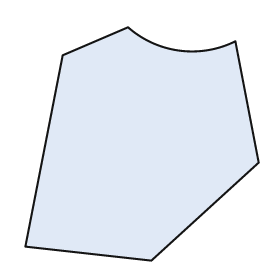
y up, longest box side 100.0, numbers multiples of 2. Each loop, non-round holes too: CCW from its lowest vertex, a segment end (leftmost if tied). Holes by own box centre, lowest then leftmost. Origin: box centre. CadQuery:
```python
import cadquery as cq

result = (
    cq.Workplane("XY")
    .moveTo(4.0, -50.0)
    .lineTo(50.0, -8.0)
    .lineTo(40.0, 44.0)
    .threePointArc((16.0, 40.0), (-6.0, 50.0))
    .lineTo(-34.0, 38.0)
    .lineTo(-50.0, -44.0)
    .close()
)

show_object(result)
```